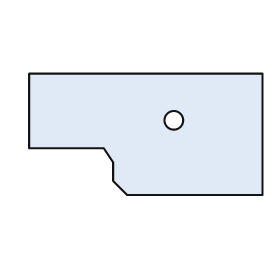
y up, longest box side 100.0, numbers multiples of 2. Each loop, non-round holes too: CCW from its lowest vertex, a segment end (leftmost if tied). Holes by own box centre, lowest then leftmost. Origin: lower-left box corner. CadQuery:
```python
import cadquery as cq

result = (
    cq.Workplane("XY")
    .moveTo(42.0, 0.0)
    .lineTo(100.0, 0.0)
    .lineTo(100.0, 52.0)
    .lineTo(0.0, 52.0)
    .lineTo(0.0, 20.0)
    .lineTo(32.0, 20.0)
    .lineTo(36.0, 14.0)
    .lineTo(36.0, 6.0)
    .close()
    .moveTo(62.0, 32.0)
    .circle(4.0)
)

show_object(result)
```